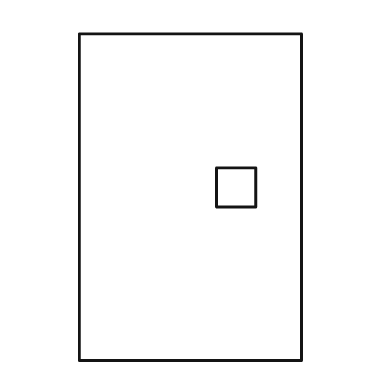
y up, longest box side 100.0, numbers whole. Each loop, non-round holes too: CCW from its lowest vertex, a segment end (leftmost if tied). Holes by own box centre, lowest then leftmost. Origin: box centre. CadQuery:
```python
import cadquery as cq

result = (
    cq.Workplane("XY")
    .moveTo(-34.0, -50.0)
    .lineTo(34.0, -50.0)
    .lineTo(34.0, 50.0)
    .lineTo(-34.0, 50.0)
    .close()
    .moveTo(8.0, -3.0)
    .lineTo(20.0, -3.0)
    .lineTo(20.0, 9.0)
    .lineTo(8.0, 9.0)
    .close()
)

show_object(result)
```